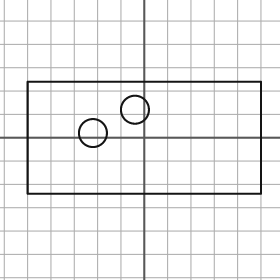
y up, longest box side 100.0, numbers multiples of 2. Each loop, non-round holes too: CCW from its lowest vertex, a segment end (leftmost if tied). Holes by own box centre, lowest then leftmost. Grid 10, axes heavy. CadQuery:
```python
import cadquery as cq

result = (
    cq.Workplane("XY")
    .moveTo(-50.0, -24.0)
    .lineTo(50.0, -24.0)
    .lineTo(50.0, 24.0)
    .lineTo(-50.0, 24.0)
    .close()
    .moveTo(-22.0, 2.0)
    .circle(6.0)
    .moveTo(-4.0, 12.0)
    .circle(6.0)
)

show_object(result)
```